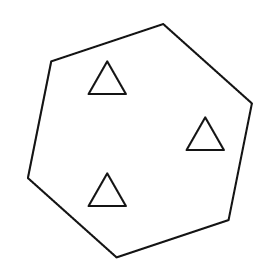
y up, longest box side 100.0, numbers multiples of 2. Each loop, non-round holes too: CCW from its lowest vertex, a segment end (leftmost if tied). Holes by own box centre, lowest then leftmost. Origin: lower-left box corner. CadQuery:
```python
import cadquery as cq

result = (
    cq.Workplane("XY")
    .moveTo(38.0, 0.0)
    .lineTo(86.0, 16.0)
    .lineTo(96.0, 66.0)
    .lineTo(58.0, 100.0)
    .lineTo(10.0, 84.0)
    .lineTo(0.0, 34.0)
    .close()
    .moveTo(26.0, 22.0)
    .lineTo(42.0, 22.0)
    .lineTo(34.0, 36.0)
    .close()
    .moveTo(68.0, 46.0)
    .lineTo(84.0, 46.0)
    .lineTo(76.0, 60.0)
    .close()
    .moveTo(26.0, 70.0)
    .lineTo(42.0, 70.0)
    .lineTo(34.0, 84.0)
    .close()
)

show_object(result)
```